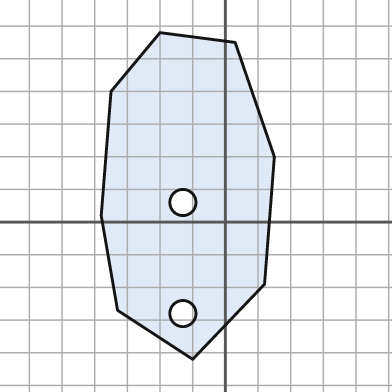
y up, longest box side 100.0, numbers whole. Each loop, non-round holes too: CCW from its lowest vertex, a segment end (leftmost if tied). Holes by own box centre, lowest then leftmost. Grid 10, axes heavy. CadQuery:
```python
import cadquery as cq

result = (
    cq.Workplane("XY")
    .moveTo(-10.0, -42.0)
    .lineTo(12.0, -19.0)
    .lineTo(15.0, 20.0)
    .lineTo(3.0, 55.0)
    .lineTo(-20.0, 58.0)
    .lineTo(-35.0, 40.0)
    .lineTo(-38.0, 2.0)
    .lineTo(-33.0, -27.0)
    .close()
    .moveTo(-13.0, -28.0)
    .circle(4.0)
    .moveTo(-13.0, 6.0)
    .circle(4.0)
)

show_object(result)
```